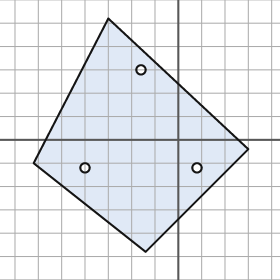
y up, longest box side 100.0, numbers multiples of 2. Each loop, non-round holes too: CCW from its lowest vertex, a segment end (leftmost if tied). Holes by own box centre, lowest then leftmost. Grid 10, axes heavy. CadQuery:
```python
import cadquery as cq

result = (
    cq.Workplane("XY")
    .moveTo(-14.0, -48.0)
    .lineTo(30.0, -4.0)
    .lineTo(-30.0, 52.0)
    .lineTo(-62.0, -10.0)
    .close()
    .moveTo(-40.0, -12.0)
    .circle(2.0)
    .moveTo(8.0, -12.0)
    .circle(2.0)
    .moveTo(-16.0, 30.0)
    .circle(2.0)
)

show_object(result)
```